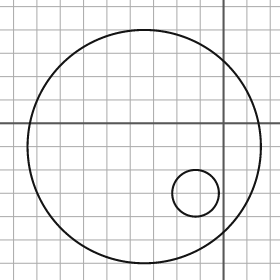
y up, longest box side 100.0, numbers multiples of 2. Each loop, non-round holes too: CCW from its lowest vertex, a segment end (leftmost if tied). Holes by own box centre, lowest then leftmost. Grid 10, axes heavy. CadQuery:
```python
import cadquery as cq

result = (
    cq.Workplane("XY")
    .moveTo(-34.0, -10.0)
    .circle(50.0)
    .moveTo(-12.0, -30.0)
    .circle(10.0)
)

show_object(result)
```